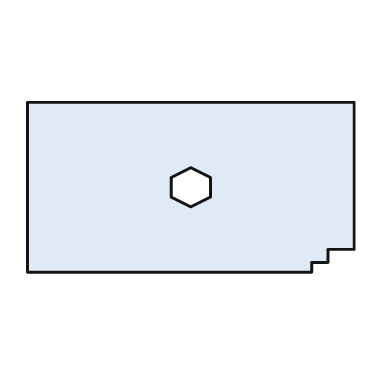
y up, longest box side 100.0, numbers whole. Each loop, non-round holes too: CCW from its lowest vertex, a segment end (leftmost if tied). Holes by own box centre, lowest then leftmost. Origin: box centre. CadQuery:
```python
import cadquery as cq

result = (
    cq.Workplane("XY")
    .moveTo(-50.0, -26.0)
    .lineTo(37.0, -26.0)
    .lineTo(37.0, -23.0)
    .lineTo(42.0, -23.0)
    .lineTo(42.0, -19.0)
    .lineTo(50.0, -19.0)
    .lineTo(50.0, 26.0)
    .lineTo(-50.0, 26.0)
    .close()
    .moveTo(0.0, -6.0)
    .lineTo(6.0, -3.0)
    .lineTo(6.0, 3.0)
    .lineTo(0.0, 6.0)
    .lineTo(-6.0, 3.0)
    .lineTo(-6.0, -3.0)
    .close()
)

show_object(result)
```